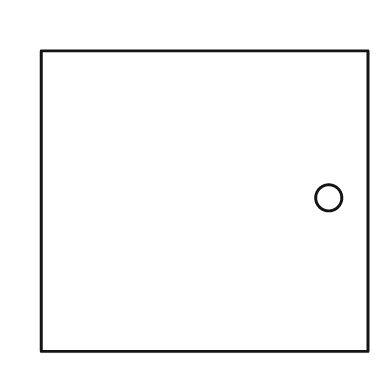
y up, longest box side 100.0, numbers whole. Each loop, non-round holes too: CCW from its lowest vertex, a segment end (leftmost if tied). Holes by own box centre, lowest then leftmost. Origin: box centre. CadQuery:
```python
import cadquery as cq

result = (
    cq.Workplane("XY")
    .moveTo(-50.0, -46.0)
    .lineTo(50.0, -46.0)
    .lineTo(50.0, 46.0)
    .lineTo(-50.0, 46.0)
    .close()
    .moveTo(38.0, 1.0)
    .circle(4.0)
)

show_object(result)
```